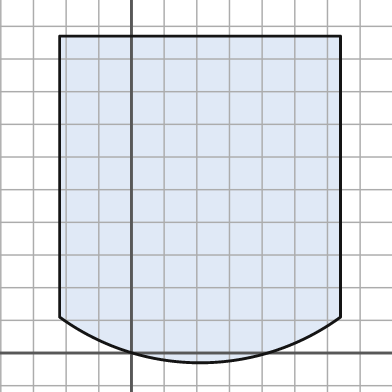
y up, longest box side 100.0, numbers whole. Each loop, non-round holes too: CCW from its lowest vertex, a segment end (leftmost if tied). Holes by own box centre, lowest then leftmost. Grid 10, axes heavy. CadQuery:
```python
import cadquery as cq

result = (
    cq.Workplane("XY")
    .moveTo(-22.0, 11.0)
    .threePointArc((21.0, -3.0), (64.0, 11.0))
    .lineTo(64.0, 97.0)
    .lineTo(-22.0, 97.0)
    .close()
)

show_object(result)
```